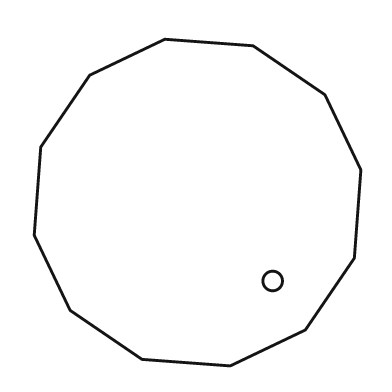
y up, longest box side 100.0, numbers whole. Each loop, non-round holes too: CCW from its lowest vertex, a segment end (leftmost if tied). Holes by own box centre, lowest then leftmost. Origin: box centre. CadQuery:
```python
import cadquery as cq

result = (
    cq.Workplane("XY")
    .moveTo(10.0, -50.0)
    .lineTo(33.0, -39.0)
    .lineTo(48.0, -17.0)
    .lineTo(50.0, 10.0)
    .lineTo(39.0, 33.0)
    .lineTo(17.0, 48.0)
    .lineTo(-10.0, 50.0)
    .lineTo(-33.0, 39.0)
    .lineTo(-48.0, 17.0)
    .lineTo(-50.0, -10.0)
    .lineTo(-39.0, -33.0)
    .lineTo(-17.0, -48.0)
    .close()
    .moveTo(23.0, -24.0)
    .circle(3.0)
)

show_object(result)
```